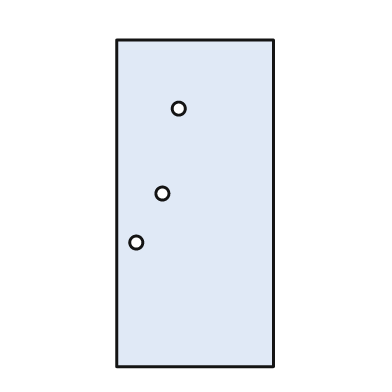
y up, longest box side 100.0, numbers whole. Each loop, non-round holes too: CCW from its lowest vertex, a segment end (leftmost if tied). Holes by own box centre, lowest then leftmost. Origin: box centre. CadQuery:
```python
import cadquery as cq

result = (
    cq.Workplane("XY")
    .moveTo(-24.0, -50.0)
    .lineTo(24.0, -50.0)
    .lineTo(24.0, 50.0)
    .lineTo(-24.0, 50.0)
    .close()
    .moveTo(-18.0, -12.0)
    .circle(2.0)
    .moveTo(-10.0, 3.0)
    .circle(2.0)
    .moveTo(-5.0, 29.0)
    .circle(2.0)
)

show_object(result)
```